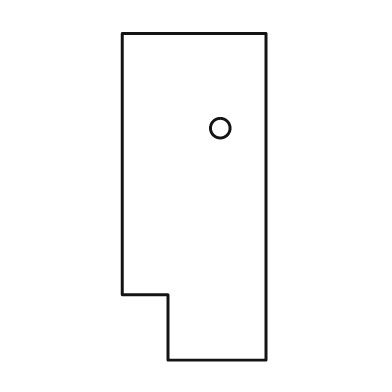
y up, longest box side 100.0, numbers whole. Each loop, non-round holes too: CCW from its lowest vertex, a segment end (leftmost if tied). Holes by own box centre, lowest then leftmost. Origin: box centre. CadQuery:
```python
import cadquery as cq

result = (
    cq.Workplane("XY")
    .moveTo(-8.0, -50.0)
    .lineTo(22.0, -50.0)
    .lineTo(22.0, 50.0)
    .lineTo(-22.0, 50.0)
    .lineTo(-22.0, -30.0)
    .lineTo(-8.0, -30.0)
    .close()
    .moveTo(8.0, 21.0)
    .circle(3.0)
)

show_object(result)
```